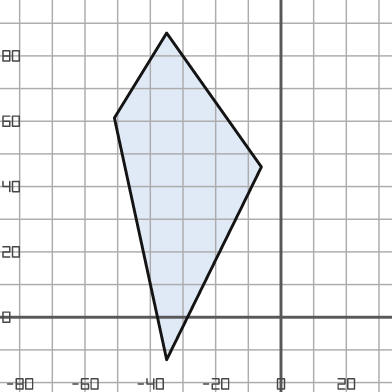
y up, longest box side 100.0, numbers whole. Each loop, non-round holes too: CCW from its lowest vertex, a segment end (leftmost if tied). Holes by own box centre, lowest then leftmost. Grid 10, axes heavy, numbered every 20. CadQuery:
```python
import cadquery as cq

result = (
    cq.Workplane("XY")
    .moveTo(-35.0, -13.0)
    .lineTo(-6.0, 46.0)
    .lineTo(-35.0, 87.0)
    .lineTo(-51.0, 61.0)
    .close()
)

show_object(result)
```